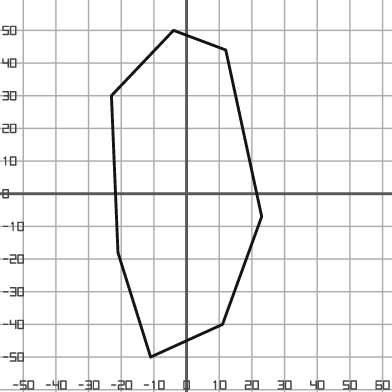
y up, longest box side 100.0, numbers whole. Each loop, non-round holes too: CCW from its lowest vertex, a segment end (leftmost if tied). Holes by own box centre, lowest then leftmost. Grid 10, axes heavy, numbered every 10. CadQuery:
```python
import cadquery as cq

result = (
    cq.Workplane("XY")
    .moveTo(-11.0, -50.0)
    .lineTo(11.0, -40.0)
    .lineTo(23.0, -7.0)
    .lineTo(12.0, 44.0)
    .lineTo(-4.0, 50.0)
    .lineTo(-23.0, 30.0)
    .lineTo(-21.0, -18.0)
    .close()
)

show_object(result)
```